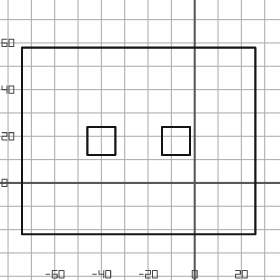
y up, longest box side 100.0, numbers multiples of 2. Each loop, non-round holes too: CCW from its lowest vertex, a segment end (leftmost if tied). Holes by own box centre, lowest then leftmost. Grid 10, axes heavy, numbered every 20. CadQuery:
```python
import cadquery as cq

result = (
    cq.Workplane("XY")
    .moveTo(-74.0, -22.0)
    .lineTo(26.0, -22.0)
    .lineTo(26.0, 58.0)
    .lineTo(-74.0, 58.0)
    .close()
    .moveTo(-46.0, 12.0)
    .lineTo(-34.0, 12.0)
    .lineTo(-34.0, 24.0)
    .lineTo(-46.0, 24.0)
    .close()
    .moveTo(-14.0, 12.0)
    .lineTo(-2.0, 12.0)
    .lineTo(-2.0, 24.0)
    .lineTo(-14.0, 24.0)
    .close()
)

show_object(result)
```